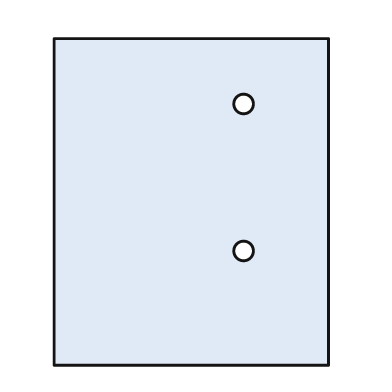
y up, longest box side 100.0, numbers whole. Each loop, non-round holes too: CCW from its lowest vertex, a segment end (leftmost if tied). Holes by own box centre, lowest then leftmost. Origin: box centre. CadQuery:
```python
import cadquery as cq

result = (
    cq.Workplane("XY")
    .moveTo(-42.0, -50.0)
    .lineTo(42.0, -50.0)
    .lineTo(42.0, 50.0)
    .lineTo(-42.0, 50.0)
    .close()
    .moveTo(16.0, -15.0)
    .circle(3.0)
    .moveTo(16.0, 30.0)
    .circle(3.0)
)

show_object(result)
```